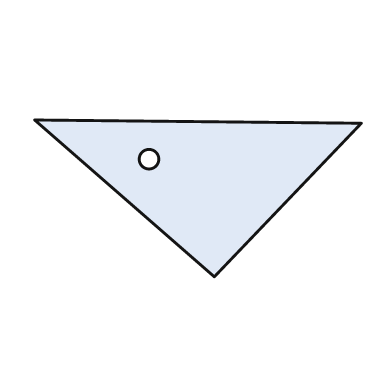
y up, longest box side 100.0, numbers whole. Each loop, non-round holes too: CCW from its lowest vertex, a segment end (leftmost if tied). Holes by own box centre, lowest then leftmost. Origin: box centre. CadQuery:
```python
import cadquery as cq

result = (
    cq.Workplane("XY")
    .moveTo(5.0, -24.0)
    .lineTo(50.0, 23.0)
    .lineTo(-50.0, 24.0)
    .close()
    .moveTo(-15.0, 12.0)
    .circle(3.0)
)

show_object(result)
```